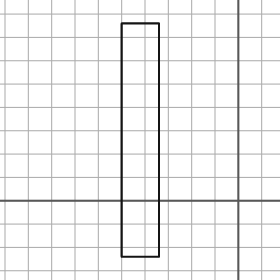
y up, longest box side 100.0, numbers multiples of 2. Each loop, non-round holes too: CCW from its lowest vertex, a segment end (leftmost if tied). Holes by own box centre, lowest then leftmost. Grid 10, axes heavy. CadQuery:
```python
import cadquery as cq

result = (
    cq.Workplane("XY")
    .moveTo(-50.0, -24.0)
    .lineTo(-34.0, -24.0)
    .lineTo(-34.0, 76.0)
    .lineTo(-50.0, 76.0)
    .close()
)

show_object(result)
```